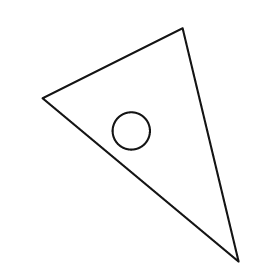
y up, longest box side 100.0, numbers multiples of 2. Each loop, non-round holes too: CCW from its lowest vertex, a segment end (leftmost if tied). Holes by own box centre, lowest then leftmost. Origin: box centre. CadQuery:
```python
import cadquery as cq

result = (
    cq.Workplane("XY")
    .moveTo(42.0, -50.0)
    .lineTo(18.0, 50.0)
    .lineTo(-42.0, 20.0)
    .close()
    .moveTo(-4.0, 6.0)
    .circle(8.0)
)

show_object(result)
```